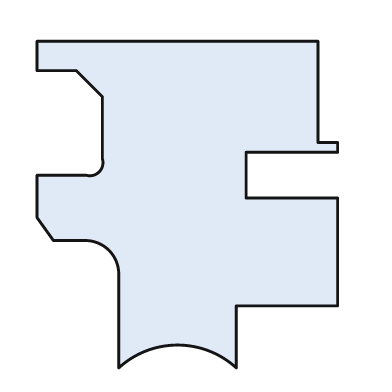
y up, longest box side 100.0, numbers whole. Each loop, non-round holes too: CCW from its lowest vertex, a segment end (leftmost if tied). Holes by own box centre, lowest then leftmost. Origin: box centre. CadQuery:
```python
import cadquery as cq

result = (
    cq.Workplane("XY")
    .moveTo(-21.0, -50.0)
    .threePointArc((-3.0, -43.0), (15.0, -50.0))
    .lineTo(15.0, -31.0)
    .lineTo(46.0, -31.0)
    .lineTo(46.0, 2.0)
    .lineTo(18.0, 2.0)
    .lineTo(18.0, 16.0)
    .lineTo(46.0, 16.0)
    .lineTo(46.0, 19.0)
    .lineTo(40.0, 19.0)
    .lineTo(40.0, 50.0)
    .lineTo(-46.0, 50.0)
    .lineTo(-46.0, 41.0)
    .lineTo(-34.0, 41.0)
    .lineTo(-26.0, 33.0)
    .lineTo(-26.0, 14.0)
    .threePointArc((-27.0, 10.0), (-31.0, 9.0))
    .lineTo(-46.0, 9.0)
    .lineTo(-46.0, -4.0)
    .lineTo(-41.0, -11.0)
    .lineTo(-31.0, -11.0)
    .threePointArc((-24.0, -14.0), (-21.0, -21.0))
    .close()
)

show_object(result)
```